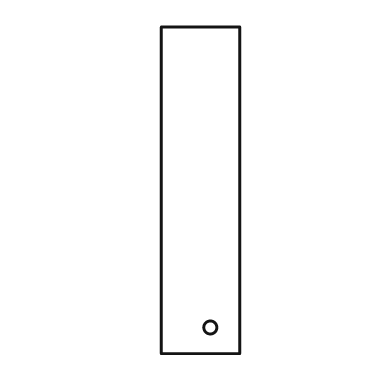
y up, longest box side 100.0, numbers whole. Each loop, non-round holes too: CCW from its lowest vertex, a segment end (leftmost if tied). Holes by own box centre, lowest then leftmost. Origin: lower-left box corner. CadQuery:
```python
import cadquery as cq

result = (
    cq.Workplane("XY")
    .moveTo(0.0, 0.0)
    .lineTo(24.0, 0.0)
    .lineTo(24.0, 100.0)
    .lineTo(0.0, 100.0)
    .close()
    .moveTo(15.0, 8.0)
    .circle(2.0)
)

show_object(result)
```